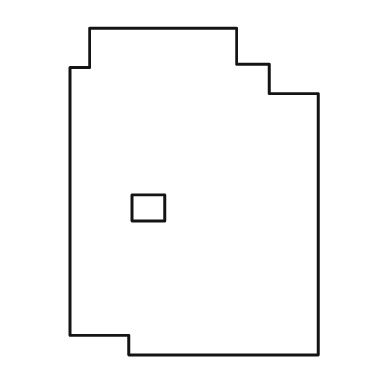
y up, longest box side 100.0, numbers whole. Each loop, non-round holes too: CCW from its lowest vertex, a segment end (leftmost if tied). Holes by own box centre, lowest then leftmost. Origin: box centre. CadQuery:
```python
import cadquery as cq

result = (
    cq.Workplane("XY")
    .moveTo(-20.0, -50.0)
    .lineTo(38.0, -50.0)
    .lineTo(38.0, 30.0)
    .lineTo(23.0, 30.0)
    .lineTo(23.0, 39.0)
    .lineTo(13.0, 39.0)
    .lineTo(13.0, 50.0)
    .lineTo(-32.0, 50.0)
    .lineTo(-32.0, 38.0)
    .lineTo(-38.0, 38.0)
    .lineTo(-38.0, -44.0)
    .lineTo(-20.0, -44.0)
    .close()
    .moveTo(-19.0, -9.0)
    .lineTo(-9.0, -9.0)
    .lineTo(-9.0, -1.0)
    .lineTo(-19.0, -1.0)
    .close()
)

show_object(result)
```